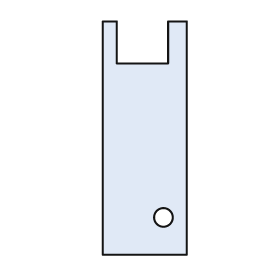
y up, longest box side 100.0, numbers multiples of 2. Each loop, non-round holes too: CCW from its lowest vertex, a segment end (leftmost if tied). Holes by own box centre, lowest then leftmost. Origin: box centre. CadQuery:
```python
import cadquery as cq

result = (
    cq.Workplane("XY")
    .moveTo(-18.0, -50.0)
    .lineTo(18.0, -50.0)
    .lineTo(18.0, 50.0)
    .lineTo(10.0, 50.0)
    .lineTo(10.0, 32.0)
    .lineTo(-12.0, 32.0)
    .lineTo(-12.0, 50.0)
    .lineTo(-18.0, 50.0)
    .close()
    .moveTo(8.0, -34.0)
    .circle(4.0)
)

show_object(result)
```